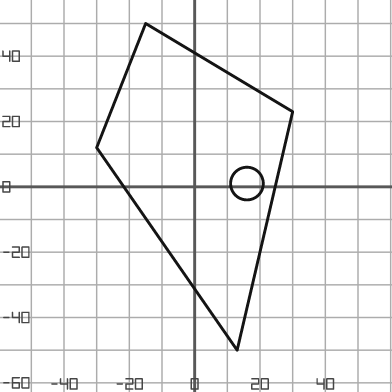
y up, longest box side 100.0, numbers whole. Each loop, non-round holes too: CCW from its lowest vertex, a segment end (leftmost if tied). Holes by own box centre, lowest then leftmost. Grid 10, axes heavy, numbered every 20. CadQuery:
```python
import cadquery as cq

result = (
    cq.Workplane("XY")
    .moveTo(13.0, -50.0)
    .lineTo(30.0, 23.0)
    .lineTo(-15.0, 50.0)
    .lineTo(-30.0, 12.0)
    .close()
    .moveTo(16.0, 1.0)
    .circle(5.0)
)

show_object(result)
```